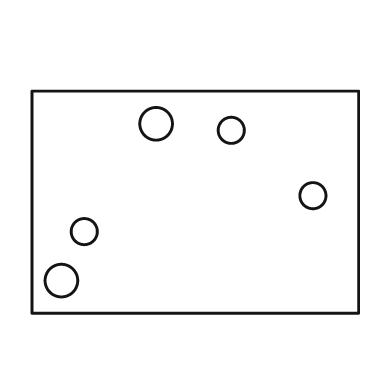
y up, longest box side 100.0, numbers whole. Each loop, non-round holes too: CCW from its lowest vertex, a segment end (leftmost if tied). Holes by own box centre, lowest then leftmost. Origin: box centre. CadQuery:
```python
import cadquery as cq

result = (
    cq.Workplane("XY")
    .moveTo(-50.0, -34.0)
    .lineTo(50.0, -34.0)
    .lineTo(50.0, 34.0)
    .lineTo(-50.0, 34.0)
    .close()
    .moveTo(-41.0, -24.0)
    .circle(5.0)
    .moveTo(-34.0, -9.0)
    .circle(4.0)
    .moveTo(36.0, 2.0)
    .circle(4.0)
    .moveTo(11.0, 22.0)
    .circle(4.0)
    .moveTo(-12.0, 24.0)
    .circle(5.0)
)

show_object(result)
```